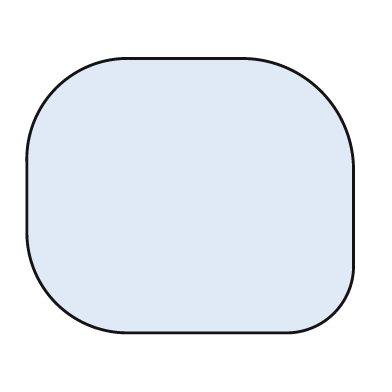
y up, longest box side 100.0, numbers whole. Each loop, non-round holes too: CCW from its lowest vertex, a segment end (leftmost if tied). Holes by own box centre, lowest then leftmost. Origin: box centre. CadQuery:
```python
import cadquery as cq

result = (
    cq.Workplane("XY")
    .moveTo(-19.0, -42.0)
    .lineTo(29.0, -42.0)
    .threePointArc((44.0, -36.0), (50.0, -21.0))
    .lineTo(50.0, 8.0)
    .threePointArc((40.0, 32.0), (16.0, 42.0))
    .lineTo(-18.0, 42.0)
    .threePointArc((-41.0, 33.0), (-50.0, 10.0))
    .lineTo(-50.0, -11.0)
    .threePointArc((-41.0, -33.0), (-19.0, -42.0))
    .close()
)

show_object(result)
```